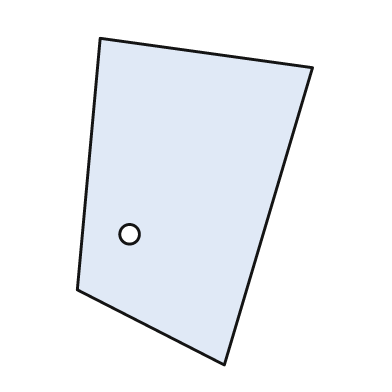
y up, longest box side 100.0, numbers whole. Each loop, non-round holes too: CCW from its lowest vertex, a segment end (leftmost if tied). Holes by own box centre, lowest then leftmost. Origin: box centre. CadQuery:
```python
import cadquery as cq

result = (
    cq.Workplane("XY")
    .moveTo(9.0, -50.0)
    .lineTo(36.0, 41.0)
    .lineTo(-29.0, 50.0)
    .lineTo(-36.0, -27.0)
    .close()
    .moveTo(-20.0, -10.0)
    .circle(3.0)
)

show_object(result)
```